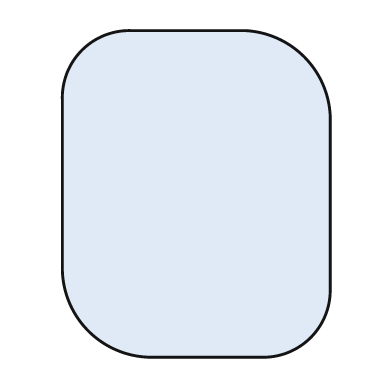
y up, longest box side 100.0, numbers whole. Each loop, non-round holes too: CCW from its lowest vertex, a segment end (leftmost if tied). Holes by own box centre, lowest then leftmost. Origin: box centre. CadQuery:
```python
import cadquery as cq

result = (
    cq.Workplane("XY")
    .moveTo(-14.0, -50.0)
    .lineTo(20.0, -50.0)
    .threePointArc((35.0, -44.0), (41.0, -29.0))
    .lineTo(41.0, 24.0)
    .threePointArc((33.0, 42.0), (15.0, 50.0))
    .lineTo(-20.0, 50.0)
    .threePointArc((-35.0, 44.0), (-41.0, 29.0))
    .lineTo(-41.0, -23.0)
    .threePointArc((-33.0, -42.0), (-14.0, -50.0))
    .close()
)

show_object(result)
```